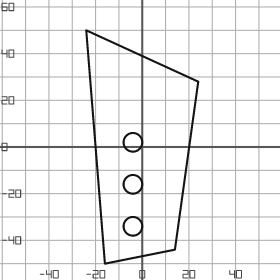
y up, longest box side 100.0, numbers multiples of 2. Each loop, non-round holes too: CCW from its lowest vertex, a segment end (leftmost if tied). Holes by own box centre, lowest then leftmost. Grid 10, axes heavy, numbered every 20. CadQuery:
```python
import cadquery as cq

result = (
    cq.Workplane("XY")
    .moveTo(-16.0, -50.0)
    .lineTo(14.0, -44.0)
    .lineTo(24.0, 28.0)
    .lineTo(-24.0, 50.0)
    .close()
    .moveTo(-4.0, -34.0)
    .circle(4.0)
    .moveTo(-4.0, -16.0)
    .circle(4.0)
    .moveTo(-4.0, 2.0)
    .circle(4.0)
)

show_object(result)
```